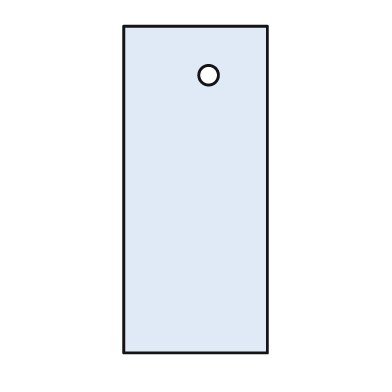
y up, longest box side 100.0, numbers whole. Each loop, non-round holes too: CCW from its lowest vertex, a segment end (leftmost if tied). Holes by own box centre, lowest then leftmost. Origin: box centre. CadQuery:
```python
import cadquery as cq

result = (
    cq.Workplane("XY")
    .moveTo(-22.0, -50.0)
    .lineTo(22.0, -50.0)
    .lineTo(22.0, 50.0)
    .lineTo(-22.0, 50.0)
    .close()
    .moveTo(4.0, 35.0)
    .circle(3.0)
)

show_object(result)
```